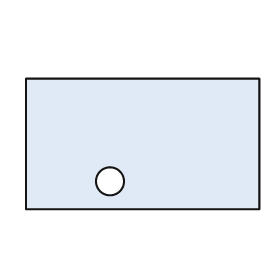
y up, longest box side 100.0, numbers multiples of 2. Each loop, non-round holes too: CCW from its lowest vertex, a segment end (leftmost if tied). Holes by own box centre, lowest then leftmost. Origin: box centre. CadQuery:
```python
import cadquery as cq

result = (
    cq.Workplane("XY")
    .moveTo(-50.0, -28.0)
    .lineTo(50.0, -28.0)
    .lineTo(50.0, 28.0)
    .lineTo(-50.0, 28.0)
    .close()
    .moveTo(-14.0, -16.0)
    .circle(6.0)
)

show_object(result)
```